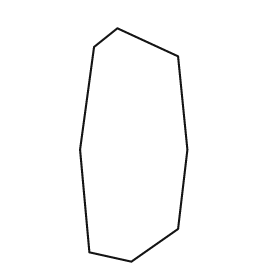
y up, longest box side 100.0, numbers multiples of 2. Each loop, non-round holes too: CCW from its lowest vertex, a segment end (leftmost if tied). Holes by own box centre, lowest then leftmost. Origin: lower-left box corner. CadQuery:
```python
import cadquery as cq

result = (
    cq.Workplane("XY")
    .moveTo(22.0, 0.0)
    .lineTo(42.0, 14.0)
    .lineTo(46.0, 48.0)
    .lineTo(42.0, 88.0)
    .lineTo(16.0, 100.0)
    .lineTo(6.0, 92.0)
    .lineTo(0.0, 48.0)
    .lineTo(4.0, 4.0)
    .close()
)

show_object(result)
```